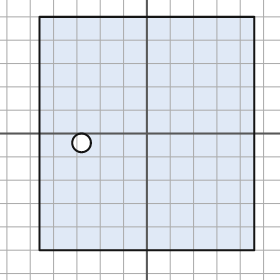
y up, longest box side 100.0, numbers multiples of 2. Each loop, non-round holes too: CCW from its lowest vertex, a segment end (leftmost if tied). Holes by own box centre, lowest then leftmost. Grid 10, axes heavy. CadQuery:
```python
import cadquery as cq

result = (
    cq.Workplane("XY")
    .moveTo(-46.0, -50.0)
    .lineTo(46.0, -50.0)
    .lineTo(46.0, 50.0)
    .lineTo(-46.0, 50.0)
    .close()
    .moveTo(-28.0, -4.0)
    .circle(4.0)
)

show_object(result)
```